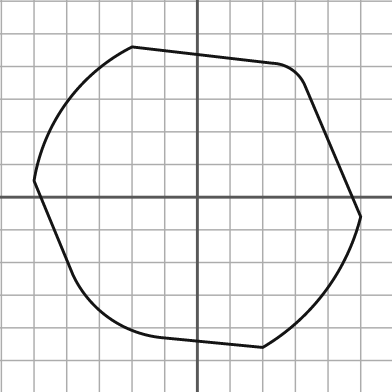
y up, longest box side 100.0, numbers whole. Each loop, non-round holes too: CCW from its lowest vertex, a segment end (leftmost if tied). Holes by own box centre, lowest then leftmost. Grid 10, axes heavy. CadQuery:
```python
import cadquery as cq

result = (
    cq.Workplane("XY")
    .moveTo(20.0, -46.0)
    .threePointArc((39.0, -29.0), (50.0, -6.0))
    .lineTo(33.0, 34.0)
    .threePointArc((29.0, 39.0), (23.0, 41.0))
    .lineTo(-20.0, 46.0)
    .threePointArc((-40.0, 29.0), (-50.0, 5.0))
    .lineTo(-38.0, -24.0)
    .threePointArc((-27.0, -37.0), (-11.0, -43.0))
    .close()
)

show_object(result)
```